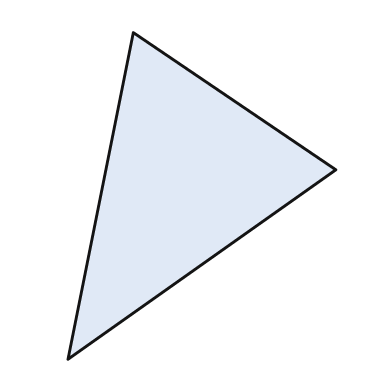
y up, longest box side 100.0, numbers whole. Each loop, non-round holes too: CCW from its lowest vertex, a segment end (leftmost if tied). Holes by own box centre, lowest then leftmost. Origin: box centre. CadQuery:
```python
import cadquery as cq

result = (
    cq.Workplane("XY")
    .moveTo(-41.0, -50.0)
    .lineTo(41.0, 8.0)
    .lineTo(-21.0, 50.0)
    .close()
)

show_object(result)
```